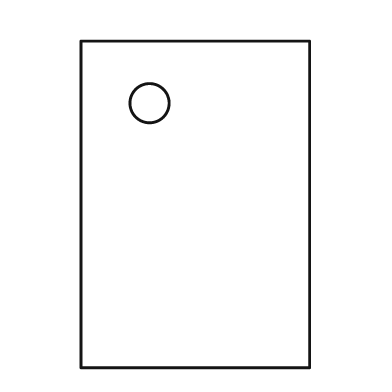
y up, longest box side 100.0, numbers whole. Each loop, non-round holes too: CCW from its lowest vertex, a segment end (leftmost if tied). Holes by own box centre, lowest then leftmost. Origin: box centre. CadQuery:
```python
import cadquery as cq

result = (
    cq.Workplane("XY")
    .moveTo(-35.0, -50.0)
    .lineTo(35.0, -50.0)
    .lineTo(35.0, 50.0)
    .lineTo(-35.0, 50.0)
    .close()
    .moveTo(-14.0, 31.0)
    .circle(6.0)
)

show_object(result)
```